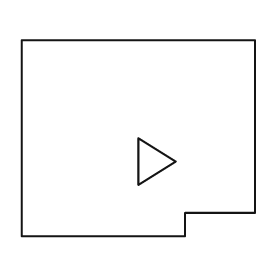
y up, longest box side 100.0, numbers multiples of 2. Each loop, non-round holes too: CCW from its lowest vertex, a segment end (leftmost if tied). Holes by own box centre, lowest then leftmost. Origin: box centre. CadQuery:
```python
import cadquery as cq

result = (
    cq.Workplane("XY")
    .moveTo(-50.0, -42.0)
    .lineTo(20.0, -42.0)
    .lineTo(20.0, -32.0)
    .lineTo(50.0, -32.0)
    .lineTo(50.0, 42.0)
    .lineTo(-50.0, 42.0)
    .close()
    .moveTo(0.0, -20.0)
    .lineTo(16.0, -10.0)
    .lineTo(0.0, 0.0)
    .close()
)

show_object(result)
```